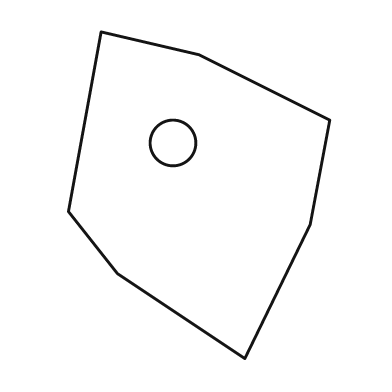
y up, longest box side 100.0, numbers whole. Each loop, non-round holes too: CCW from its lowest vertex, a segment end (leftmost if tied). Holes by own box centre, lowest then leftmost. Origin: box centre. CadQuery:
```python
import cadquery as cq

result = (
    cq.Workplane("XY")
    .moveTo(14.0, -50.0)
    .lineTo(34.0, -9.0)
    .lineTo(40.0, 23.0)
    .lineTo(0.0, 43.0)
    .lineTo(-30.0, 50.0)
    .lineTo(-40.0, -5.0)
    .lineTo(-25.0, -24.0)
    .close()
    .moveTo(-8.0, 16.0)
    .circle(7.0)
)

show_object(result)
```